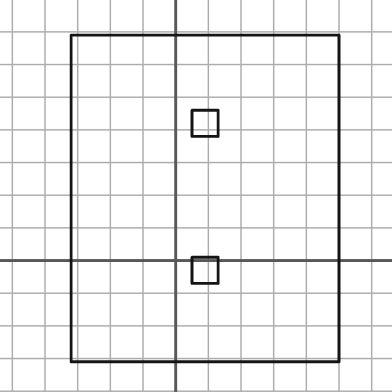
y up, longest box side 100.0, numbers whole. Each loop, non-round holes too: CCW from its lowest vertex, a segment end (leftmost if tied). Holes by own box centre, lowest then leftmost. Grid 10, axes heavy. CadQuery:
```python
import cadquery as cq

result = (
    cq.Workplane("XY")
    .moveTo(-32.0, -31.0)
    .lineTo(50.0, -31.0)
    .lineTo(50.0, 69.0)
    .lineTo(-32.0, 69.0)
    .close()
    .moveTo(5.0, -7.0)
    .lineTo(13.0, -7.0)
    .lineTo(13.0, 1.0)
    .lineTo(5.0, 1.0)
    .close()
    .moveTo(5.0, 38.0)
    .lineTo(13.0, 38.0)
    .lineTo(13.0, 46.0)
    .lineTo(5.0, 46.0)
    .close()
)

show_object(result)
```